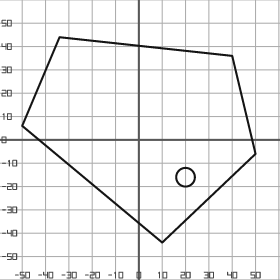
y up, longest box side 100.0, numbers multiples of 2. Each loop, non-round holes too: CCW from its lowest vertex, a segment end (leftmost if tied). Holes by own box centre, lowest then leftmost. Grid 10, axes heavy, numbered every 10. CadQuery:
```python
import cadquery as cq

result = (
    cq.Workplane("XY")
    .moveTo(10.0, -44.0)
    .lineTo(50.0, -6.0)
    .lineTo(40.0, 36.0)
    .lineTo(-34.0, 44.0)
    .lineTo(-50.0, 6.0)
    .close()
    .moveTo(20.0, -16.0)
    .circle(4.0)
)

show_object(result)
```